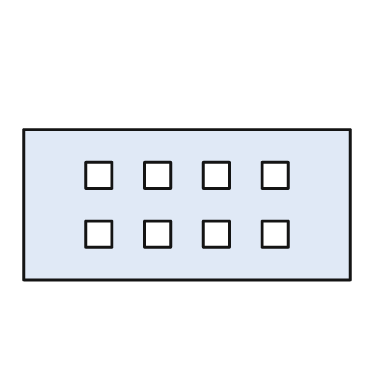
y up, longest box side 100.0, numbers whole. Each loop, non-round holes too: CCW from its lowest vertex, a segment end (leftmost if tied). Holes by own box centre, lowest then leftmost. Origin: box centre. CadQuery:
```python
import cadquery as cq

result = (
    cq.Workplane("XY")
    .moveTo(-50.0, -23.0)
    .lineTo(50.0, -23.0)
    .lineTo(50.0, 23.0)
    .lineTo(-50.0, 23.0)
    .close()
    .moveTo(-31.0, -13.0)
    .lineTo(-23.0, -13.0)
    .lineTo(-23.0, -5.0)
    .lineTo(-31.0, -5.0)
    .close()
    .moveTo(-13.0, -13.0)
    .lineTo(-5.0, -13.0)
    .lineTo(-5.0, -5.0)
    .lineTo(-13.0, -5.0)
    .close()
    .moveTo(5.0, -13.0)
    .lineTo(13.0, -13.0)
    .lineTo(13.0, -5.0)
    .lineTo(5.0, -5.0)
    .close()
    .moveTo(23.0, -13.0)
    .lineTo(31.0, -13.0)
    .lineTo(31.0, -5.0)
    .lineTo(23.0, -5.0)
    .close()
    .moveTo(-31.0, 5.0)
    .lineTo(-23.0, 5.0)
    .lineTo(-23.0, 13.0)
    .lineTo(-31.0, 13.0)
    .close()
    .moveTo(-13.0, 5.0)
    .lineTo(-5.0, 5.0)
    .lineTo(-5.0, 13.0)
    .lineTo(-13.0, 13.0)
    .close()
    .moveTo(5.0, 5.0)
    .lineTo(13.0, 5.0)
    .lineTo(13.0, 13.0)
    .lineTo(5.0, 13.0)
    .close()
    .moveTo(23.0, 5.0)
    .lineTo(31.0, 5.0)
    .lineTo(31.0, 13.0)
    .lineTo(23.0, 13.0)
    .close()
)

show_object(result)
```